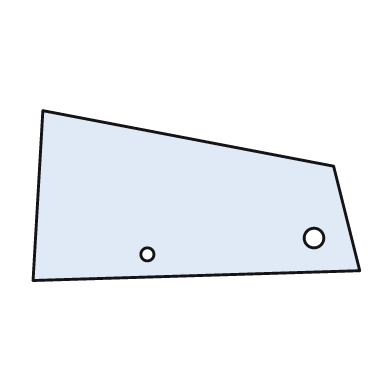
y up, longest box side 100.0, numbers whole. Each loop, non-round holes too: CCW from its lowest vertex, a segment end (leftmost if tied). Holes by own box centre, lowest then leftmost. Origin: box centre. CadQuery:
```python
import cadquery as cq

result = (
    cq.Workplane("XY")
    .moveTo(-50.0, -26.0)
    .lineTo(50.0, -23.0)
    .lineTo(42.0, 9.0)
    .lineTo(-47.0, 26.0)
    .close()
    .moveTo(-15.0, -18.0)
    .circle(2.0)
    .moveTo(36.0, -13.0)
    .circle(3.0)
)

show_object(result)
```